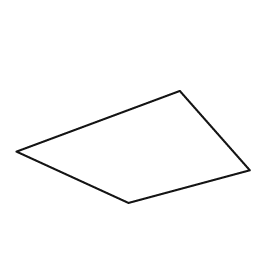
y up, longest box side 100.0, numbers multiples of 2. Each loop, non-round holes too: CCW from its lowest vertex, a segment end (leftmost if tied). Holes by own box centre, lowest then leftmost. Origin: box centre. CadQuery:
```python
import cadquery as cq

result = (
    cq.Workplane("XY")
    .moveTo(-2.0, -24.0)
    .lineTo(50.0, -10.0)
    .lineTo(20.0, 24.0)
    .lineTo(-50.0, -2.0)
    .close()
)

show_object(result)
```